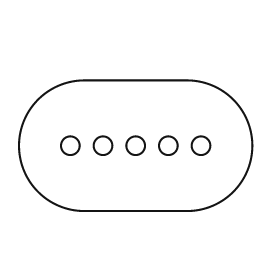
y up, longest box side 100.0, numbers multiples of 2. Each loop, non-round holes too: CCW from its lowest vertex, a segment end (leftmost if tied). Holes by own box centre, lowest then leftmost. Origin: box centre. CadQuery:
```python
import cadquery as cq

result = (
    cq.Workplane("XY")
    .moveTo(-22.0, -28.0)
    .lineTo(22.0, -28.0)
    .threePointArc((50.0, 0.0), (22.0, 28.0))
    .lineTo(-22.0, 28.0)
    .threePointArc((-50.0, 0.0), (-22.0, -28.0))
    .close()
    .moveTo(-28.0, 0.0)
    .circle(4.0)
    .moveTo(-14.0, 0.0)
    .circle(4.0)
    .moveTo(0.0, 0.0)
    .circle(4.0)
    .moveTo(14.0, 0.0)
    .circle(4.0)
    .moveTo(28.0, 0.0)
    .circle(4.0)
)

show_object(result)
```